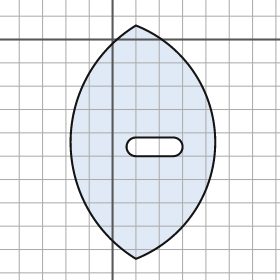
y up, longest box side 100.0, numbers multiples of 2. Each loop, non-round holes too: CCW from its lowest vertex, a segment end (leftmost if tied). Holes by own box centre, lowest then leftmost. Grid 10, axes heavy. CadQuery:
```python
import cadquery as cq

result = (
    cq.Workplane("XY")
    .moveTo(10.0, -94.0)
    .threePointArc((44.0, -44.0), (10.0, 6.0))
    .threePointArc((-18.0, -44.0), (10.0, -94.0))
    .close()
    .moveTo(10.0, -50.0)
    .lineTo(26.0, -50.0)
    .threePointArc((30.0, -46.0), (26.0, -42.0))
    .lineTo(10.0, -42.0)
    .threePointArc((6.0, -46.0), (10.0, -50.0))
    .close()
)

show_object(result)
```